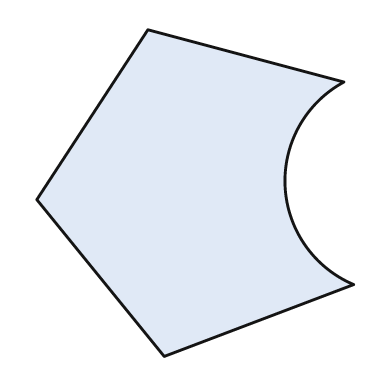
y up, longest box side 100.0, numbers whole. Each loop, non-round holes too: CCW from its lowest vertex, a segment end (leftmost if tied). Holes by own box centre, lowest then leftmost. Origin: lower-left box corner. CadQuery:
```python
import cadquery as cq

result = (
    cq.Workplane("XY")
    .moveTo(39.0, 0.0)
    .lineTo(97.0, 22.0)
    .threePointArc((76.0, 52.0), (94.0, 84.0))
    .lineTo(34.0, 100.0)
    .lineTo(0.0, 48.0)
    .close()
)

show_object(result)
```